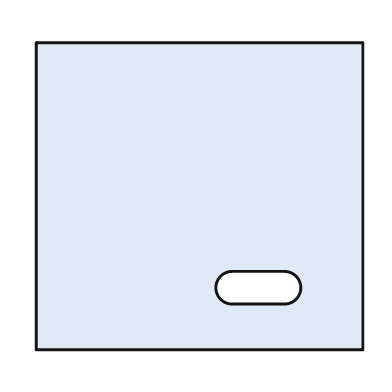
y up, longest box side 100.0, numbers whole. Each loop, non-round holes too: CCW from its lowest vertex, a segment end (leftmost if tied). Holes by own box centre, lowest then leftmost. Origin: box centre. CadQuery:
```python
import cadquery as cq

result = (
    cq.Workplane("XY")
    .moveTo(-50.0, -47.0)
    .lineTo(50.0, -47.0)
    .lineTo(50.0, 47.0)
    .lineTo(-50.0, 47.0)
    .close()
    .moveTo(10.0, -33.0)
    .lineTo(26.0, -33.0)
    .threePointArc((31.0, -28.0), (26.0, -23.0))
    .lineTo(10.0, -23.0)
    .threePointArc((5.0, -28.0), (10.0, -33.0))
    .close()
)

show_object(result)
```